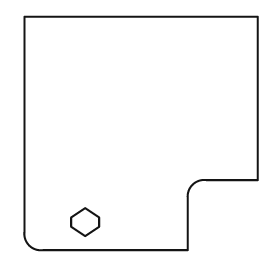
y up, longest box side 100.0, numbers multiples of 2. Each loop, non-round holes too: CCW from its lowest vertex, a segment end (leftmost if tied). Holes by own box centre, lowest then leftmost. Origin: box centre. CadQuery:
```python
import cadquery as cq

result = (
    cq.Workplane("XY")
    .moveTo(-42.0, -50.0)
    .lineTo(20.0, -50.0)
    .lineTo(20.0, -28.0)
    .threePointArc((22.0, -22.0), (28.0, -20.0))
    .lineTo(50.0, -20.0)
    .lineTo(50.0, 50.0)
    .lineTo(-50.0, 50.0)
    .lineTo(-50.0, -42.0)
    .threePointArc((-48.0, -48.0), (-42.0, -50.0))
    .close()
    .moveTo(-24.0, -44.0)
    .lineTo(-18.0, -40.0)
    .lineTo(-18.0, -36.0)
    .lineTo(-24.0, -32.0)
    .lineTo(-30.0, -36.0)
    .lineTo(-30.0, -40.0)
    .close()
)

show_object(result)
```